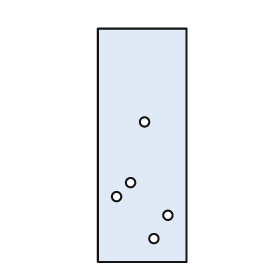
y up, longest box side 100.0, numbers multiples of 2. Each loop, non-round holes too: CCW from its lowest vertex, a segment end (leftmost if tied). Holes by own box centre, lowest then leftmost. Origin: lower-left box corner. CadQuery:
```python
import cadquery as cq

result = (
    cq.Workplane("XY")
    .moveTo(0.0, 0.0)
    .lineTo(38.0, 0.0)
    .lineTo(38.0, 100.0)
    .lineTo(0.0, 100.0)
    .close()
    .moveTo(24.0, 10.0)
    .circle(2.0)
    .moveTo(30.0, 20.0)
    .circle(2.0)
    .moveTo(8.0, 28.0)
    .circle(2.0)
    .moveTo(14.0, 34.0)
    .circle(2.0)
    .moveTo(20.0, 60.0)
    .circle(2.0)
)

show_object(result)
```